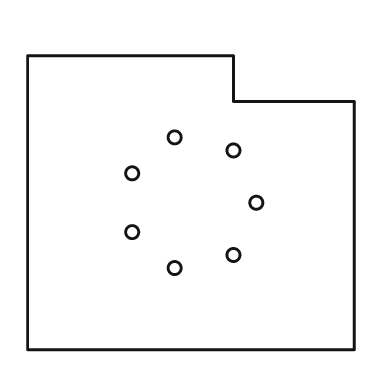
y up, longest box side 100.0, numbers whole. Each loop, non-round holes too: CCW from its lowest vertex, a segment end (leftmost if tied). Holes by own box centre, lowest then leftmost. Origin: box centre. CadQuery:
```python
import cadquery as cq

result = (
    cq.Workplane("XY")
    .moveTo(-50.0, -45.0)
    .lineTo(50.0, -45.0)
    .lineTo(50.0, 31.0)
    .lineTo(13.0, 31.0)
    .lineTo(13.0, 45.0)
    .lineTo(-50.0, 45.0)
    .close()
    .moveTo(-5.0, -20.0)
    .circle(2.0)
    .moveTo(13.0, -16.0)
    .circle(2.0)
    .moveTo(-18.0, -9.0)
    .circle(2.0)
    .moveTo(20.0, 0.0)
    .circle(2.0)
    .moveTo(-18.0, 9.0)
    .circle(2.0)
    .moveTo(13.0, 16.0)
    .circle(2.0)
    .moveTo(-5.0, 20.0)
    .circle(2.0)
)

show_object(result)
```